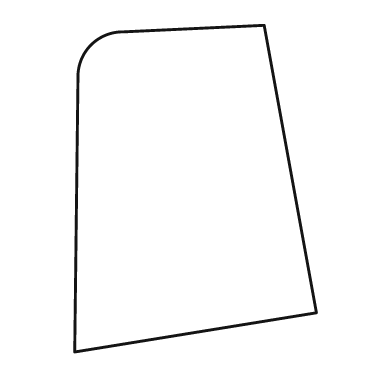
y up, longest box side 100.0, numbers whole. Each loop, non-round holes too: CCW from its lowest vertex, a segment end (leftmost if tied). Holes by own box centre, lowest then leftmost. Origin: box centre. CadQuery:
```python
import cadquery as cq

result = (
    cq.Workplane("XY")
    .moveTo(-37.0, -50.0)
    .lineTo(37.0, -38.0)
    .lineTo(21.0, 50.0)
    .lineTo(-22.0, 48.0)
    .threePointArc((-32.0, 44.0), (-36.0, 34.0))
    .close()
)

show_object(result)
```